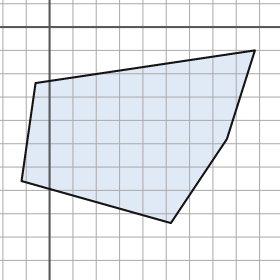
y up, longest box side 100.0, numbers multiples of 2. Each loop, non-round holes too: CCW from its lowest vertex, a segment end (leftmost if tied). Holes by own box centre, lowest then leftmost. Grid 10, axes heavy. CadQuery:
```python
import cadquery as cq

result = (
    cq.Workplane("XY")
    .moveTo(52.0, -84.0)
    .lineTo(76.0, -48.0)
    .lineTo(88.0, -10.0)
    .lineTo(-6.0, -24.0)
    .lineTo(-12.0, -66.0)
    .close()
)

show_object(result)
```